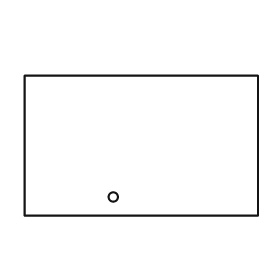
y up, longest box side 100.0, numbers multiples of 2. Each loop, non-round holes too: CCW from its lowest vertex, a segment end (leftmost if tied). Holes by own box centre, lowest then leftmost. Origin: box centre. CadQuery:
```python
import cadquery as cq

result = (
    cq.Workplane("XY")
    .moveTo(-50.0, -30.0)
    .lineTo(50.0, -30.0)
    .lineTo(50.0, 30.0)
    .lineTo(-50.0, 30.0)
    .close()
    .moveTo(-12.0, -22.0)
    .circle(2.0)
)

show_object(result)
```